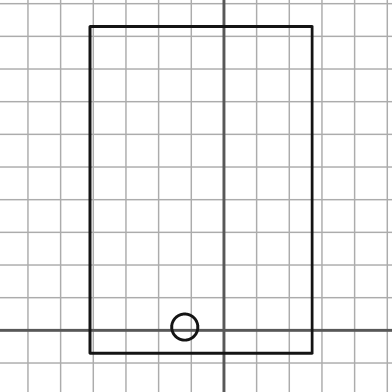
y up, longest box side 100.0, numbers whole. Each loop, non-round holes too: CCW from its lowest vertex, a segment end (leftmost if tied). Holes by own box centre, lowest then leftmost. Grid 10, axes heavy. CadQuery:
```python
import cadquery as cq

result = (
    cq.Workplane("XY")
    .moveTo(-41.0, -7.0)
    .lineTo(27.0, -7.0)
    .lineTo(27.0, 93.0)
    .lineTo(-41.0, 93.0)
    .close()
    .moveTo(-12.0, 1.0)
    .circle(4.0)
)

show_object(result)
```